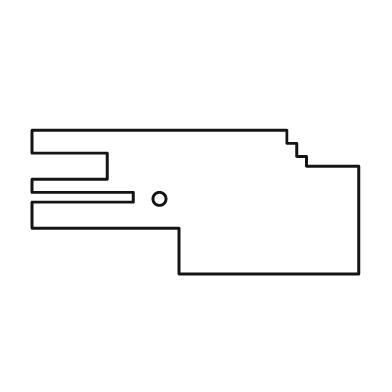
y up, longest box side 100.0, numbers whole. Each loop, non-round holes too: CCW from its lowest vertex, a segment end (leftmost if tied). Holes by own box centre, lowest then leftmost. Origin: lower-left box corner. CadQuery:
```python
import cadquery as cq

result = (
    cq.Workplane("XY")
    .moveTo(45.0, 0.0)
    .lineTo(100.0, 0.0)
    .lineTo(100.0, 33.0)
    .lineTo(84.0, 33.0)
    .lineTo(84.0, 36.0)
    .lineTo(81.0, 36.0)
    .lineTo(81.0, 40.0)
    .lineTo(78.0, 40.0)
    .lineTo(78.0, 44.0)
    .lineTo(0.0, 44.0)
    .lineTo(0.0, 37.0)
    .lineTo(23.0, 37.0)
    .lineTo(23.0, 29.0)
    .lineTo(0.0, 29.0)
    .lineTo(0.0, 25.0)
    .lineTo(31.0, 25.0)
    .lineTo(31.0, 22.0)
    .lineTo(0.0, 22.0)
    .lineTo(0.0, 14.0)
    .lineTo(45.0, 14.0)
    .close()
    .moveTo(39.0, 23.0)
    .circle(2.0)
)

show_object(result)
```